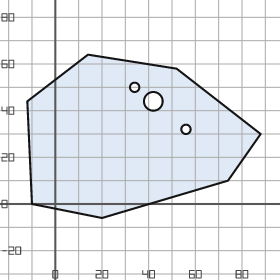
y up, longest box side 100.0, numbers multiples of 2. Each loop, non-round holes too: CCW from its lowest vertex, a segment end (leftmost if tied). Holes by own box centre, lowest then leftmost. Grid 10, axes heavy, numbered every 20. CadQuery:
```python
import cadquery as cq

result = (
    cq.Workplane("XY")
    .moveTo(20.0, -6.0)
    .lineTo(74.0, 10.0)
    .lineTo(88.0, 30.0)
    .lineTo(52.0, 58.0)
    .lineTo(14.0, 64.0)
    .lineTo(-12.0, 44.0)
    .lineTo(-10.0, 0.0)
    .close()
    .moveTo(56.0, 32.0)
    .circle(2.0)
    .moveTo(42.0, 44.0)
    .circle(4.0)
    .moveTo(34.0, 50.0)
    .circle(2.0)
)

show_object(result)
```